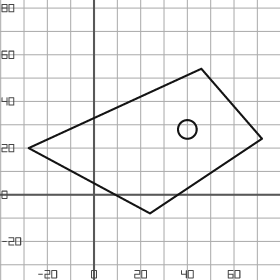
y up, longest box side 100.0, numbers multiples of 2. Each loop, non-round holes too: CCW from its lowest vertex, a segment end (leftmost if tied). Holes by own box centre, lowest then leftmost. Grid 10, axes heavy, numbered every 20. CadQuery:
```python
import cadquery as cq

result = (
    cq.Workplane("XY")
    .moveTo(24.0, -8.0)
    .lineTo(72.0, 24.0)
    .lineTo(46.0, 54.0)
    .lineTo(-28.0, 20.0)
    .close()
    .moveTo(40.0, 28.0)
    .circle(4.0)
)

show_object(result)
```